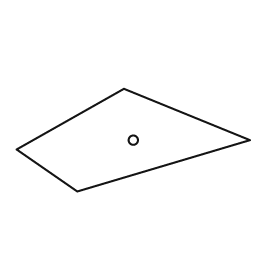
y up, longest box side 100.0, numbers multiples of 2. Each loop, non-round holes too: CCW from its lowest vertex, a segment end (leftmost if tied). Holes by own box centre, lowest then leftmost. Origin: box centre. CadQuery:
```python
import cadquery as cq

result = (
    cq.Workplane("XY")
    .moveTo(-24.0, -22.0)
    .lineTo(50.0, 0.0)
    .lineTo(-4.0, 22.0)
    .lineTo(-50.0, -4.0)
    .close()
    .moveTo(0.0, 0.0)
    .circle(2.0)
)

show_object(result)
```